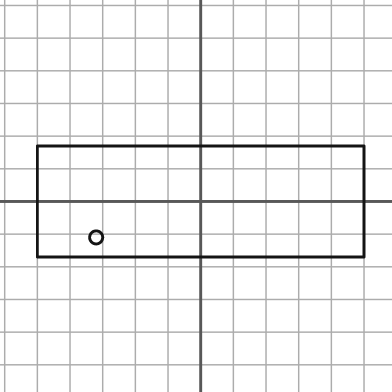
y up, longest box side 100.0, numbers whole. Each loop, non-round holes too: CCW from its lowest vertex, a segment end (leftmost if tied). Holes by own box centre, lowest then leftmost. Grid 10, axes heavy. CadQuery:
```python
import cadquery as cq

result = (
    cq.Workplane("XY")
    .moveTo(-50.0, -17.0)
    .lineTo(50.0, -17.0)
    .lineTo(50.0, 17.0)
    .lineTo(-50.0, 17.0)
    .close()
    .moveTo(-32.0, -11.0)
    .circle(2.0)
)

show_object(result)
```